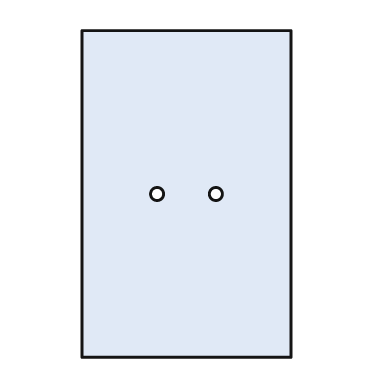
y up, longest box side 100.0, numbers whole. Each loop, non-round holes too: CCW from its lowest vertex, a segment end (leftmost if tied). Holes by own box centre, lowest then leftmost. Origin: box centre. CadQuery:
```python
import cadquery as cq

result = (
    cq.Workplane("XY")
    .moveTo(-32.0, -50.0)
    .lineTo(32.0, -50.0)
    .lineTo(32.0, 50.0)
    .lineTo(-32.0, 50.0)
    .close()
    .moveTo(-9.0, 0.0)
    .circle(2.0)
    .moveTo(9.0, 0.0)
    .circle(2.0)
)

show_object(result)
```